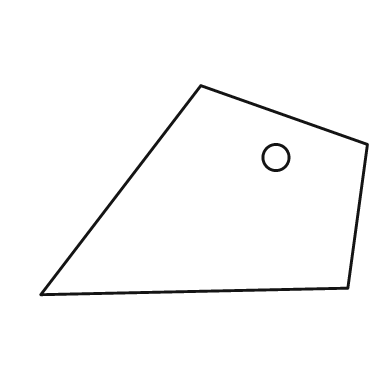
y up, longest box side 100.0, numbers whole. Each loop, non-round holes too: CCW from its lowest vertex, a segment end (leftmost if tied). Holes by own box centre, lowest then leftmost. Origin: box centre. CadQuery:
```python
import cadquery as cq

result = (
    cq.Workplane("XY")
    .moveTo(-50.0, -32.0)
    .lineTo(44.0, -30.0)
    .lineTo(50.0, 14.0)
    .lineTo(-1.0, 32.0)
    .close()
    .moveTo(22.0, 10.0)
    .circle(4.0)
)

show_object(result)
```